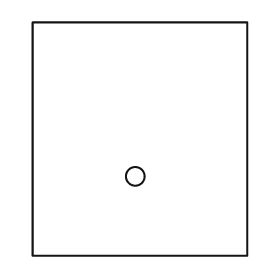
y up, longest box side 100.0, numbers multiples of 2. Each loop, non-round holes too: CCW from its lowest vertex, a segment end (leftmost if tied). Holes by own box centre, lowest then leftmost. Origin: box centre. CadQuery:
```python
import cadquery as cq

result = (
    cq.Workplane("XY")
    .moveTo(-46.0, -50.0)
    .lineTo(46.0, -50.0)
    .lineTo(46.0, 50.0)
    .lineTo(-46.0, 50.0)
    .close()
    .moveTo(-2.0, -16.0)
    .circle(4.0)
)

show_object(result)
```